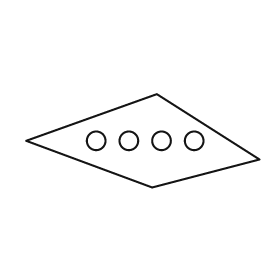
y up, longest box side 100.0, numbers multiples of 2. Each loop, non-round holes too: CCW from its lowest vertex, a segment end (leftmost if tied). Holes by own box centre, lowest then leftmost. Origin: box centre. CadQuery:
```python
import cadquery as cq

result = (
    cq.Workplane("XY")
    .moveTo(4.0, -20.0)
    .lineTo(50.0, -8.0)
    .lineTo(6.0, 20.0)
    .lineTo(-50.0, 0.0)
    .close()
    .moveTo(-20.0, 0.0)
    .circle(4.0)
    .moveTo(-6.0, 0.0)
    .circle(4.0)
    .moveTo(8.0, 0.0)
    .circle(4.0)
    .moveTo(22.0, 0.0)
    .circle(4.0)
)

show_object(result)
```